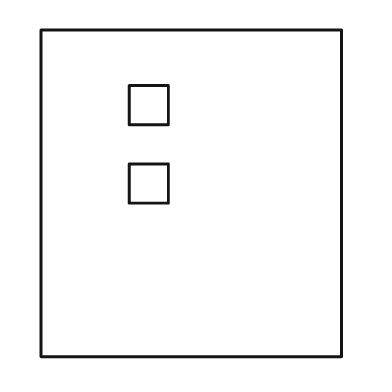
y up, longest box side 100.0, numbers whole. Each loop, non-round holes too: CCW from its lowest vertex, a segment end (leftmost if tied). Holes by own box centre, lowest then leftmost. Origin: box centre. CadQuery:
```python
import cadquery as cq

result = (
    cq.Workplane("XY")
    .moveTo(-46.0, -50.0)
    .lineTo(46.0, -50.0)
    .lineTo(46.0, 50.0)
    .lineTo(-46.0, 50.0)
    .close()
    .moveTo(-19.0, -3.0)
    .lineTo(-7.0, -3.0)
    .lineTo(-7.0, 9.0)
    .lineTo(-19.0, 9.0)
    .close()
    .moveTo(-19.0, 21.0)
    .lineTo(-7.0, 21.0)
    .lineTo(-7.0, 33.0)
    .lineTo(-19.0, 33.0)
    .close()
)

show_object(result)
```